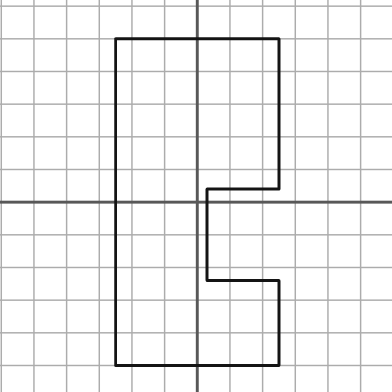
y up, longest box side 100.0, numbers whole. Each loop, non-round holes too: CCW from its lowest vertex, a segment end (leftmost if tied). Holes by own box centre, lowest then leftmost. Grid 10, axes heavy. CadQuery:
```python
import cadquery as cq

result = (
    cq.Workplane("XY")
    .moveTo(-25.0, -50.0)
    .lineTo(25.0, -50.0)
    .lineTo(25.0, -24.0)
    .lineTo(3.0, -24.0)
    .lineTo(3.0, 4.0)
    .lineTo(25.0, 4.0)
    .lineTo(25.0, 50.0)
    .lineTo(-25.0, 50.0)
    .close()
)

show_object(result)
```